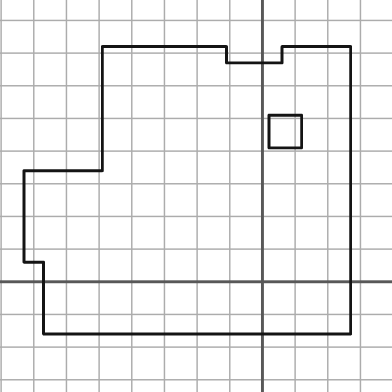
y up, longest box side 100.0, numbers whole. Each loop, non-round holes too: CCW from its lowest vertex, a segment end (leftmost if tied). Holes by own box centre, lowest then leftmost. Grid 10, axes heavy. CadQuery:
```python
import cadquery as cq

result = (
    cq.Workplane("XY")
    .moveTo(-67.0, -16.0)
    .lineTo(27.0, -16.0)
    .lineTo(27.0, 72.0)
    .lineTo(6.0, 72.0)
    .lineTo(6.0, 67.0)
    .lineTo(-11.0, 67.0)
    .lineTo(-11.0, 72.0)
    .lineTo(-49.0, 72.0)
    .lineTo(-49.0, 34.0)
    .lineTo(-73.0, 34.0)
    .lineTo(-73.0, 6.0)
    .lineTo(-67.0, 6.0)
    .close()
    .moveTo(2.0, 41.0)
    .lineTo(12.0, 41.0)
    .lineTo(12.0, 51.0)
    .lineTo(2.0, 51.0)
    .close()
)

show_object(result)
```